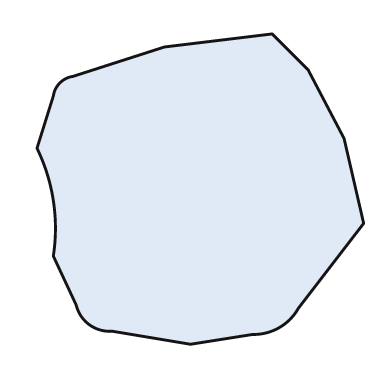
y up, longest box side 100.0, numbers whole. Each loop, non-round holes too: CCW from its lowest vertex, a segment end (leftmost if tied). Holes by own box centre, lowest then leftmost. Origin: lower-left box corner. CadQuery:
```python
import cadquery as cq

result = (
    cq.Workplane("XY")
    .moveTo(47.0, 0.0)
    .lineTo(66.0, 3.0)
    .threePointArc((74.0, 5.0), (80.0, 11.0))
    .lineTo(100.0, 37.0)
    .lineTo(94.0, 63.0)
    .lineTo(83.0, 84.0)
    .lineTo(72.0, 95.0)
    .lineTo(39.0, 91.0)
    .lineTo(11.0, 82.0)
    .threePointArc((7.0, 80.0), (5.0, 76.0))
    .lineTo(0.0, 60.0)
    .threePointArc((5.0, 44.0), (5.0, 27.0))
    .lineTo(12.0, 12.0)
    .threePointArc((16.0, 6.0), (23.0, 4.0))
    .close()
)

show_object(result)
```